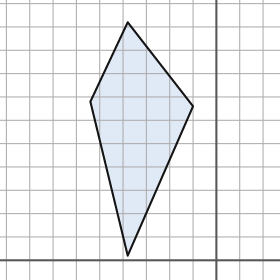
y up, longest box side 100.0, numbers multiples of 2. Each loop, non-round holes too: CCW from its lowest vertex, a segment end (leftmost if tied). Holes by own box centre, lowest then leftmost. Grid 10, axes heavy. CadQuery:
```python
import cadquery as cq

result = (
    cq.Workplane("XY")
    .moveTo(-38.0, 2.0)
    .lineTo(-10.0, 66.0)
    .lineTo(-38.0, 102.0)
    .lineTo(-54.0, 68.0)
    .close()
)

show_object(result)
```